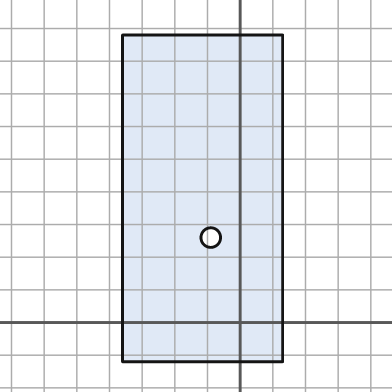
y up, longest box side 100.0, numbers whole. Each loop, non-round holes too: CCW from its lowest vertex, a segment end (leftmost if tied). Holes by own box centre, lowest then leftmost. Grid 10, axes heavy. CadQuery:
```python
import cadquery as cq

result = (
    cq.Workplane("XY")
    .moveTo(-36.0, -12.0)
    .lineTo(13.0, -12.0)
    .lineTo(13.0, 88.0)
    .lineTo(-36.0, 88.0)
    .close()
    .moveTo(-9.0, 26.0)
    .circle(3.0)
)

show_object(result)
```